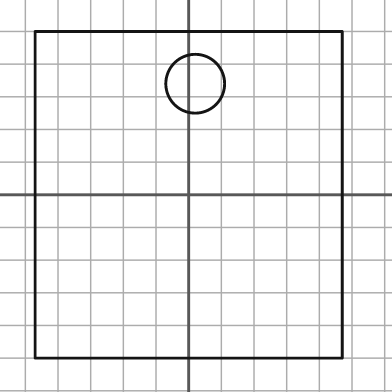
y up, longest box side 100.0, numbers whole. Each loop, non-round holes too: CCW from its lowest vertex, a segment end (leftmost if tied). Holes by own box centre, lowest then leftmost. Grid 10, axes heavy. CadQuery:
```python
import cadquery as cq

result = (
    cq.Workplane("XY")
    .moveTo(-47.0, -50.0)
    .lineTo(47.0, -50.0)
    .lineTo(47.0, 50.0)
    .lineTo(-47.0, 50.0)
    .close()
    .moveTo(2.0, 34.0)
    .circle(9.0)
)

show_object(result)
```